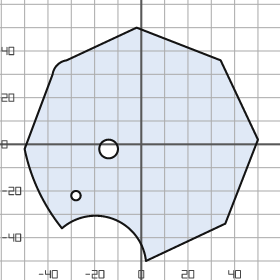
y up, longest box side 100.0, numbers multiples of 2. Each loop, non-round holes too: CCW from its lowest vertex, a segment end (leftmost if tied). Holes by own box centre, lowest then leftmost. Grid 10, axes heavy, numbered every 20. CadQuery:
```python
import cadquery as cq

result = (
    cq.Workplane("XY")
    .moveTo(2.0, -50.0)
    .lineTo(36.0, -34.0)
    .lineTo(50.0, 2.0)
    .lineTo(34.0, 36.0)
    .lineTo(-2.0, 50.0)
    .lineTo(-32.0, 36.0)
    .threePointArc((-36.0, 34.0), (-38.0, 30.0))
    .lineTo(-50.0, -2.0)
    .threePointArc((-44.0, -20.0), (-34.0, -36.0))
    .threePointArc((-12.0, -32.0), (2.0, -50.0))
    .close()
    .moveTo(-28.0, -22.0)
    .circle(2.0)
    .moveTo(-14.0, -2.0)
    .circle(4.0)
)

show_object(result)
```